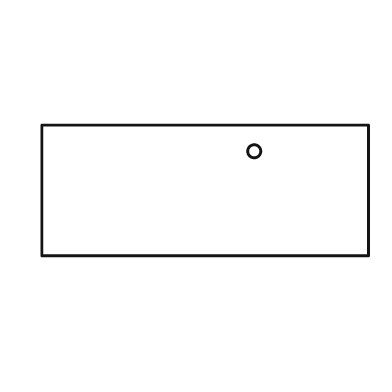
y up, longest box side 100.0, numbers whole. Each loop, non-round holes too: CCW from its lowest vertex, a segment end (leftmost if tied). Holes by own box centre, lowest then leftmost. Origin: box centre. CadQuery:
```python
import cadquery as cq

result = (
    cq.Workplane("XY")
    .moveTo(-50.0, -20.0)
    .lineTo(50.0, -20.0)
    .lineTo(50.0, 20.0)
    .lineTo(-50.0, 20.0)
    .close()
    .moveTo(15.0, 12.0)
    .circle(2.0)
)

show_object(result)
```